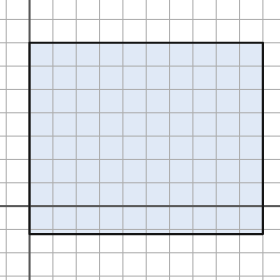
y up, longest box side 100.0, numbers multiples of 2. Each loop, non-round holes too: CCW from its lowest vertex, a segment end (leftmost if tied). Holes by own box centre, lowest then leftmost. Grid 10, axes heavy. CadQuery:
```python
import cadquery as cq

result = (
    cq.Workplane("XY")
    .moveTo(0.0, -12.0)
    .lineTo(100.0, -12.0)
    .lineTo(100.0, 70.0)
    .lineTo(0.0, 70.0)
    .close()
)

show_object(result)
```